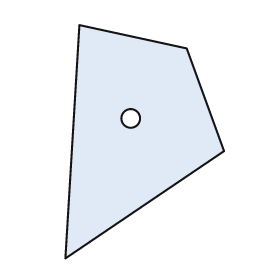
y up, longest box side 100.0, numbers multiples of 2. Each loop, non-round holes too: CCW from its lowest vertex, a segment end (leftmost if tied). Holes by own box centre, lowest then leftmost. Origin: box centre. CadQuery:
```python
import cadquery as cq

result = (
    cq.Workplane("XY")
    .moveTo(-34.0, -50.0)
    .lineTo(34.0, -4.0)
    .lineTo(18.0, 40.0)
    .lineTo(-28.0, 50.0)
    .close()
    .moveTo(-6.0, 10.0)
    .circle(4.0)
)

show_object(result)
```